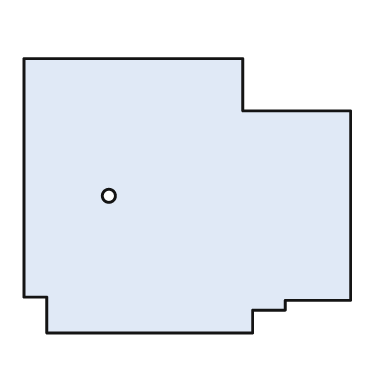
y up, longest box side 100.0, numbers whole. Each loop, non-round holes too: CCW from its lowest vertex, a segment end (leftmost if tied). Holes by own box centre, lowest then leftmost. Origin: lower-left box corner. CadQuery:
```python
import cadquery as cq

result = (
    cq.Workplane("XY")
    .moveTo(7.0, 0.0)
    .lineTo(70.0, 0.0)
    .lineTo(70.0, 7.0)
    .lineTo(80.0, 7.0)
    .lineTo(80.0, 10.0)
    .lineTo(100.0, 10.0)
    .lineTo(100.0, 68.0)
    .lineTo(67.0, 68.0)
    .lineTo(67.0, 84.0)
    .lineTo(0.0, 84.0)
    .lineTo(0.0, 11.0)
    .lineTo(7.0, 11.0)
    .close()
    .moveTo(26.0, 42.0)
    .circle(2.0)
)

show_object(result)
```